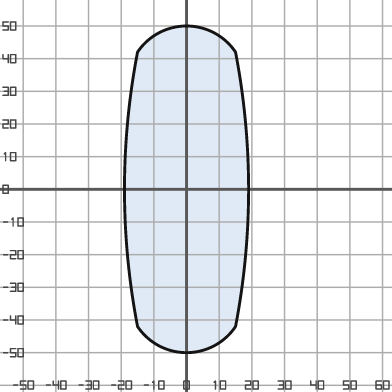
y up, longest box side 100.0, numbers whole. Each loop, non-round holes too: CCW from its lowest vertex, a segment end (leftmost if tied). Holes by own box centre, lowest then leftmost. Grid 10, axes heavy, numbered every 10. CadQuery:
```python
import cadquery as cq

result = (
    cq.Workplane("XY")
    .moveTo(-15.0, -42.0)
    .threePointArc((0.0, -50.0), (15.0, -42.0))
    .threePointArc((19.0, 0.0), (15.0, 42.0))
    .threePointArc((0.0, 50.0), (-15.0, 42.0))
    .threePointArc((-19.0, 0.0), (-15.0, -42.0))
    .close()
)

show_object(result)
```